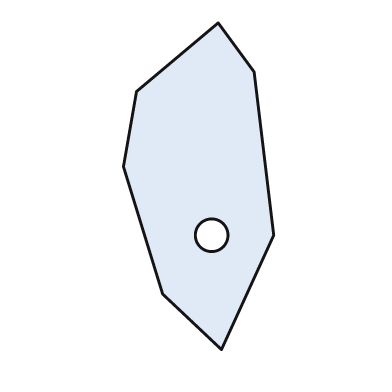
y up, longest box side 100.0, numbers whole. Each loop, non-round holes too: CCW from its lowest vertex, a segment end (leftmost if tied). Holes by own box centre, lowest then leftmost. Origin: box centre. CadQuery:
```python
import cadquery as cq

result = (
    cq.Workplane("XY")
    .moveTo(7.0, -50.0)
    .lineTo(23.0, -15.0)
    .lineTo(17.0, 35.0)
    .lineTo(6.0, 50.0)
    .lineTo(-19.0, 29.0)
    .lineTo(-23.0, 6.0)
    .lineTo(-11.0, -33.0)
    .close()
    .moveTo(4.0, -15.0)
    .circle(5.0)
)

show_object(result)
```